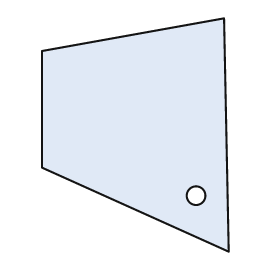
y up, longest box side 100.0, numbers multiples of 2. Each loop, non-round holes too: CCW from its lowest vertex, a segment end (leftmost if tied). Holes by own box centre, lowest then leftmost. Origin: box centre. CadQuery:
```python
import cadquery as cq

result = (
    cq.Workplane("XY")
    .moveTo(40.0, -50.0)
    .lineTo(38.0, 50.0)
    .lineTo(-40.0, 36.0)
    .lineTo(-40.0, -14.0)
    .close()
    .moveTo(26.0, -26.0)
    .circle(4.0)
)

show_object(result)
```